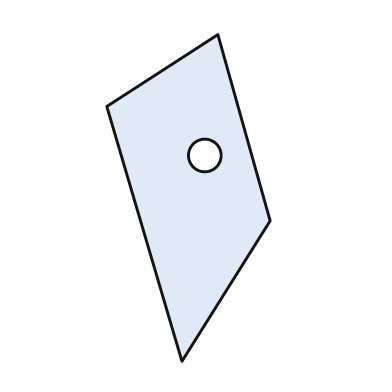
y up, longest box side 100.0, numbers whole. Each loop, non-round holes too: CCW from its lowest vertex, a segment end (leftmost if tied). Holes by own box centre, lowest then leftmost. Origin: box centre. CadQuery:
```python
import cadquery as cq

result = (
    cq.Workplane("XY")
    .moveTo(-2.0, -50.0)
    .lineTo(25.0, -7.0)
    .lineTo(9.0, 50.0)
    .lineTo(-25.0, 28.0)
    .close()
    .moveTo(5.0, 13.0)
    .circle(5.0)
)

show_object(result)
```